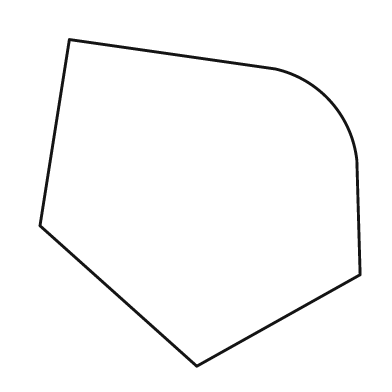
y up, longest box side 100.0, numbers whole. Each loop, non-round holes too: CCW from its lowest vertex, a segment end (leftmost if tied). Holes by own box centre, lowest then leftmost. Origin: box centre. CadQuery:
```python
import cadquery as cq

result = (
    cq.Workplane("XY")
    .moveTo(-1.0, -50.0)
    .lineTo(49.0, -22.0)
    .lineTo(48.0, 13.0)
    .threePointArc((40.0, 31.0), (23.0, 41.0))
    .lineTo(-40.0, 50.0)
    .lineTo(-49.0, -7.0)
    .close()
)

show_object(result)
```